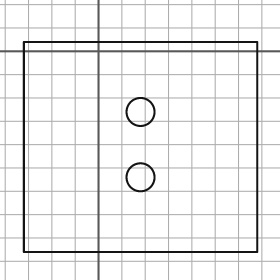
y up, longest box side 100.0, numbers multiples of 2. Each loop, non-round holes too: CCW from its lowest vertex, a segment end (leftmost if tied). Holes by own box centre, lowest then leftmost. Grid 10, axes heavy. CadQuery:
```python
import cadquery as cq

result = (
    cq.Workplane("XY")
    .moveTo(-32.0, -86.0)
    .lineTo(68.0, -86.0)
    .lineTo(68.0, 4.0)
    .lineTo(-32.0, 4.0)
    .close()
    .moveTo(18.0, -54.0)
    .circle(6.0)
    .moveTo(18.0, -26.0)
    .circle(6.0)
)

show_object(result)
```